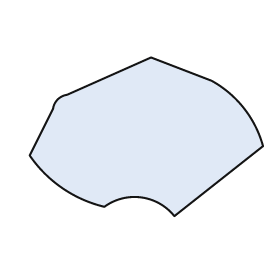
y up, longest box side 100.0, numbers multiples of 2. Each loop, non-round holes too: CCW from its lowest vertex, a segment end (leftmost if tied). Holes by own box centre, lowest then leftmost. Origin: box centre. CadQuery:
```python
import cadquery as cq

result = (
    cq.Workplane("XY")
    .moveTo(12.0, -34.0)
    .lineTo(50.0, -4.0)
    .threePointArc((42.0, 12.0), (28.0, 24.0))
    .lineTo(2.0, 34.0)
    .lineTo(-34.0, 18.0)
    .threePointArc((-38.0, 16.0), (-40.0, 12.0))
    .lineTo(-50.0, -8.0)
    .threePointArc((-36.0, -22.0), (-18.0, -30.0))
    .threePointArc((-2.0, -26.0), (12.0, -34.0))
    .close()
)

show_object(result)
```